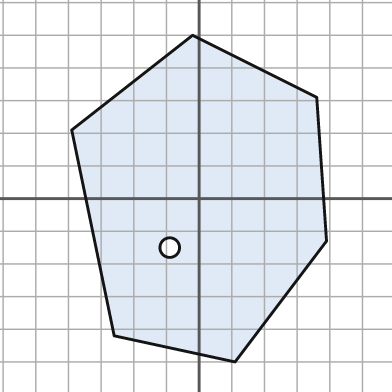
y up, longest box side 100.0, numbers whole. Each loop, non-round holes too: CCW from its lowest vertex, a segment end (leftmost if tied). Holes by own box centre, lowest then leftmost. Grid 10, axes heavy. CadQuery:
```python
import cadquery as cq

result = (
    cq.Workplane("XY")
    .moveTo(11.0, -50.0)
    .lineTo(39.0, -13.0)
    .lineTo(36.0, 31.0)
    .lineTo(-2.0, 50.0)
    .lineTo(-39.0, 21.0)
    .lineTo(-26.0, -42.0)
    .close()
    .moveTo(-9.0, -15.0)
    .circle(3.0)
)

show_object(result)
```